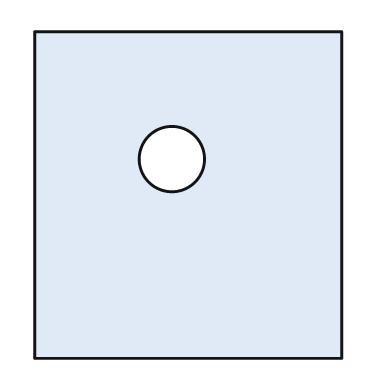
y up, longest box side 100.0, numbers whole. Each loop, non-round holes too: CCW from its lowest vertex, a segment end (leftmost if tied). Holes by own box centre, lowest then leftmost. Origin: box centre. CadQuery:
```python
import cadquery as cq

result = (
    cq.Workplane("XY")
    .moveTo(-47.0, -50.0)
    .lineTo(47.0, -50.0)
    .lineTo(47.0, 50.0)
    .lineTo(-47.0, 50.0)
    .close()
    .moveTo(-5.0, 11.0)
    .circle(10.0)
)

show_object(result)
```